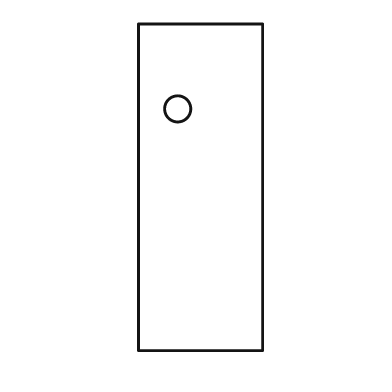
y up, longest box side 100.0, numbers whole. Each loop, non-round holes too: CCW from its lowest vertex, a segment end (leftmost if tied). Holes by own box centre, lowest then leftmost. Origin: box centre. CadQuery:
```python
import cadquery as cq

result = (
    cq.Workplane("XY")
    .moveTo(-19.0, -50.0)
    .lineTo(19.0, -50.0)
    .lineTo(19.0, 50.0)
    .lineTo(-19.0, 50.0)
    .close()
    .moveTo(-7.0, 24.0)
    .circle(4.0)
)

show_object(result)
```